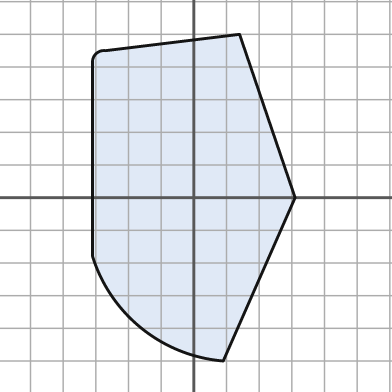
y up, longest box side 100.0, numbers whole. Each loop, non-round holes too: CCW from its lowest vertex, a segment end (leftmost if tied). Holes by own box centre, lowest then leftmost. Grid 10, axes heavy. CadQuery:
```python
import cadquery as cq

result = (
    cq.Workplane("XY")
    .moveTo(9.0, -50.0)
    .lineTo(31.0, 0.0)
    .lineTo(14.0, 50.0)
    .lineTo(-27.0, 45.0)
    .threePointArc((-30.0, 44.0), (-31.0, 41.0))
    .lineTo(-31.0, -18.0)
    .threePointArc((-16.0, -40.0), (9.0, -50.0))
    .close()
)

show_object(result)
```